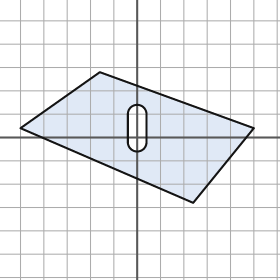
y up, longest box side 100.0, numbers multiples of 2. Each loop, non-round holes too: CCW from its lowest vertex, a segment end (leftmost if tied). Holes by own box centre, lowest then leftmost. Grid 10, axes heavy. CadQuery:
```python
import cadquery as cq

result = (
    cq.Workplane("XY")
    .moveTo(24.0, -28.0)
    .lineTo(50.0, 4.0)
    .lineTo(-16.0, 28.0)
    .lineTo(-50.0, 4.0)
    .close()
    .moveTo(-4.0, -2.0)
    .threePointArc((0.0, -6.0), (4.0, -2.0))
    .lineTo(4.0, 10.0)
    .threePointArc((0.0, 14.0), (-4.0, 10.0))
    .close()
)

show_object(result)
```